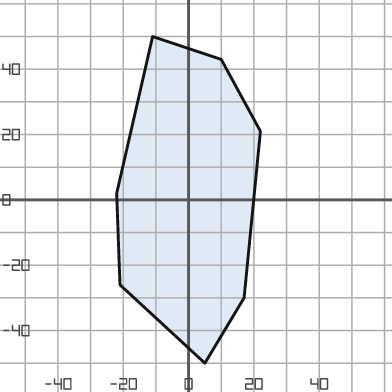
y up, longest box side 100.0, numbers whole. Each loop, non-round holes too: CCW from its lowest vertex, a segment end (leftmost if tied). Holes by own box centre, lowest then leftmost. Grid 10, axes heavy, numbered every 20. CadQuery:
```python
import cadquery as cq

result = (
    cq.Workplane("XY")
    .moveTo(5.0, -50.0)
    .lineTo(17.0, -30.0)
    .lineTo(22.0, 21.0)
    .lineTo(10.0, 43.0)
    .lineTo(-11.0, 50.0)
    .lineTo(-22.0, 2.0)
    .lineTo(-21.0, -26.0)
    .close()
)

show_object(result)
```